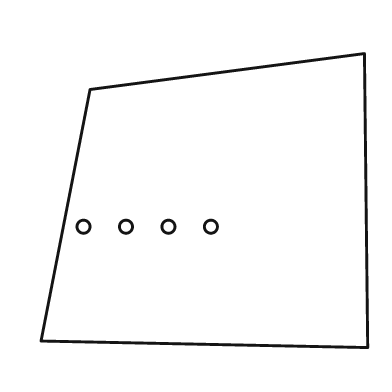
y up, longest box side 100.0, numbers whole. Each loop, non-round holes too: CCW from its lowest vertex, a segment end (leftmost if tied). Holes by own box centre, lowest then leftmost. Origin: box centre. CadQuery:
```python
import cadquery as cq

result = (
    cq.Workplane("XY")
    .moveTo(50.0, -45.0)
    .lineTo(49.0, 45.0)
    .lineTo(-35.0, 34.0)
    .lineTo(-50.0, -43.0)
    .close()
    .moveTo(-37.0, -8.0)
    .circle(2.0)
    .moveTo(-24.0, -8.0)
    .circle(2.0)
    .moveTo(-11.0, -8.0)
    .circle(2.0)
    .moveTo(2.0, -8.0)
    .circle(2.0)
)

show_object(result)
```